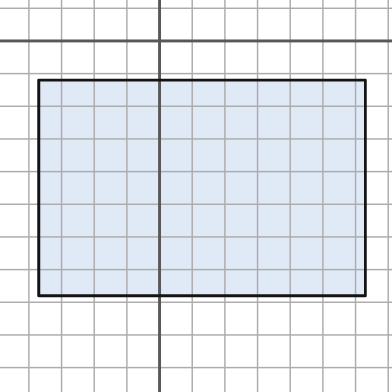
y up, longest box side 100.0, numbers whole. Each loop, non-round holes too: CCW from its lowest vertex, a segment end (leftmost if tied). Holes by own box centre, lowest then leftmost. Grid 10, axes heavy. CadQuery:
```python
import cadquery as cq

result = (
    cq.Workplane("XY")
    .moveTo(-37.0, -78.0)
    .lineTo(63.0, -78.0)
    .lineTo(63.0, -12.0)
    .lineTo(-37.0, -12.0)
    .close()
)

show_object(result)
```